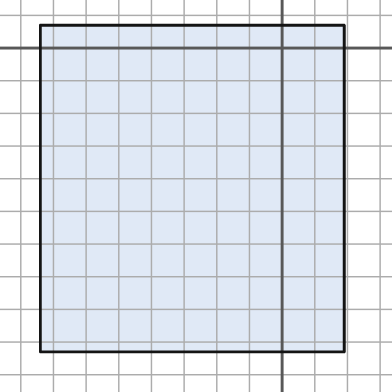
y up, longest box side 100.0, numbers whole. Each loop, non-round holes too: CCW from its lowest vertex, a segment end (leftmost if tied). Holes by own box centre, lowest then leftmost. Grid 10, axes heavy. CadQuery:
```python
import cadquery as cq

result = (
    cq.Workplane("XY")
    .moveTo(-74.0, -93.0)
    .lineTo(19.0, -93.0)
    .lineTo(19.0, 7.0)
    .lineTo(-74.0, 7.0)
    .close()
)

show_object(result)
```